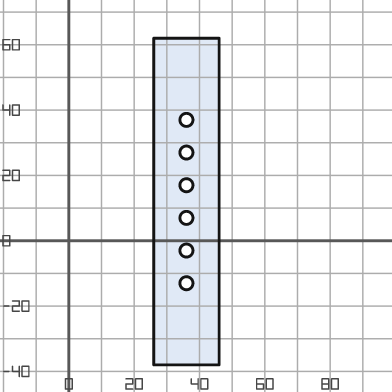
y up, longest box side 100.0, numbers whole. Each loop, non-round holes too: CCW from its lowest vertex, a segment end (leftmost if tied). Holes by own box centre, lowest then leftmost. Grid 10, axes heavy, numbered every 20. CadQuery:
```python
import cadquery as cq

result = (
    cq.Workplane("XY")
    .moveTo(26.0, -38.0)
    .lineTo(46.0, -38.0)
    .lineTo(46.0, 62.0)
    .lineTo(26.0, 62.0)
    .close()
    .moveTo(36.0, -13.0)
    .circle(2.0)
    .moveTo(36.0, -3.0)
    .circle(2.0)
    .moveTo(36.0, 7.0)
    .circle(2.0)
    .moveTo(36.0, 17.0)
    .circle(2.0)
    .moveTo(36.0, 27.0)
    .circle(2.0)
    .moveTo(36.0, 37.0)
    .circle(2.0)
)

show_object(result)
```